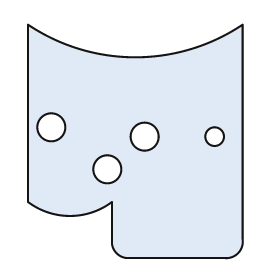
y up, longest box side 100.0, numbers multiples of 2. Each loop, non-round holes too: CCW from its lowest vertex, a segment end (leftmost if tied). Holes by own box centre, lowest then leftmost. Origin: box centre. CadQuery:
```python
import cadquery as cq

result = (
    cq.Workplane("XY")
    .moveTo(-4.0, -50.0)
    .lineTo(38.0, -50.0)
    .threePointArc((44.0, -48.0), (46.0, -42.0))
    .lineTo(46.0, 50.0)
    .threePointArc((0.0, 36.0), (-46.0, 50.0))
    .lineTo(-46.0, -26.0)
    .threePointArc((-28.0, -32.0), (-10.0, -26.0))
    .lineTo(-10.0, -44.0)
    .threePointArc((-8.0, -48.0), (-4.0, -50.0))
    .close()
    .moveTo(-12.0, -12.0)
    .circle(6.0)
    .moveTo(4.0, 2.0)
    .circle(6.0)
    .moveTo(34.0, 2.0)
    .circle(4.0)
    .moveTo(-36.0, 6.0)
    .circle(6.0)
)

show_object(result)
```